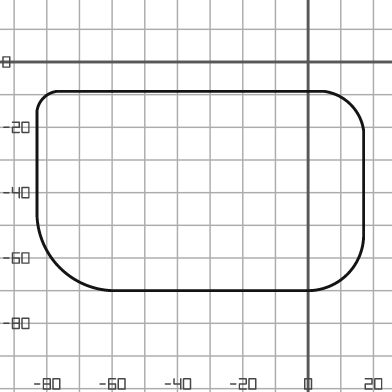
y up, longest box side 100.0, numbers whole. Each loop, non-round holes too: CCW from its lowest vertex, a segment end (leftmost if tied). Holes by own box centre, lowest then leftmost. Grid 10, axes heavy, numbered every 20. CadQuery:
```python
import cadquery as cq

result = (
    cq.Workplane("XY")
    .moveTo(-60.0, -70.0)
    .lineTo(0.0, -70.0)
    .threePointArc((12.0, -65.0), (17.0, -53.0))
    .lineTo(17.0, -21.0)
    .threePointArc((13.0, -13.0), (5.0, -9.0))
    .lineTo(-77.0, -9.0)
    .threePointArc((-81.0, -11.0), (-83.0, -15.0))
    .lineTo(-83.0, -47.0)
    .threePointArc((-76.0, -63.0), (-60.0, -70.0))
    .close()
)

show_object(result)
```